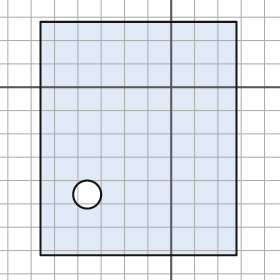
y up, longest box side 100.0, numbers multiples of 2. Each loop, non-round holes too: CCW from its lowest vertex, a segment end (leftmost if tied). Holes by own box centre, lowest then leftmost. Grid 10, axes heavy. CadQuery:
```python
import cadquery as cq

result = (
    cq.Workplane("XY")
    .moveTo(-56.0, -72.0)
    .lineTo(28.0, -72.0)
    .lineTo(28.0, 28.0)
    .lineTo(-56.0, 28.0)
    .close()
    .moveTo(-36.0, -46.0)
    .circle(6.0)
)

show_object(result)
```